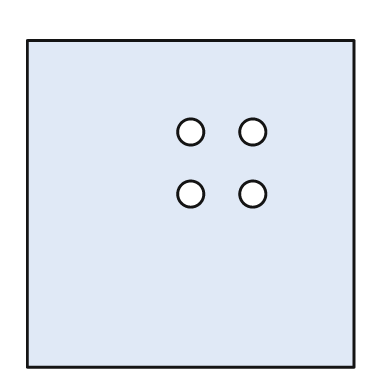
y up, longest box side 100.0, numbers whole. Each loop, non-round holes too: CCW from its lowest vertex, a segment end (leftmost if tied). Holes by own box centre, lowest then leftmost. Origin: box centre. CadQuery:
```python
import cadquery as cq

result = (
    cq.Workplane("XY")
    .moveTo(-50.0, -50.0)
    .lineTo(50.0, -50.0)
    .lineTo(50.0, 50.0)
    .lineTo(-50.0, 50.0)
    .close()
    .moveTo(0.0, 3.0)
    .circle(4.0)
    .moveTo(19.0, 3.0)
    .circle(4.0)
    .moveTo(0.0, 22.0)
    .circle(4.0)
    .moveTo(19.0, 22.0)
    .circle(4.0)
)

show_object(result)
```